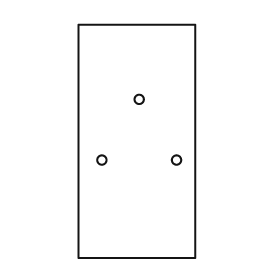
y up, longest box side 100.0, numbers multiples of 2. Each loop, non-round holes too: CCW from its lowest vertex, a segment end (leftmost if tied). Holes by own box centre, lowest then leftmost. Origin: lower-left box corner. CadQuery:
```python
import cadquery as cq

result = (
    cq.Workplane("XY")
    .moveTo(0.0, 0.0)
    .lineTo(50.0, 0.0)
    .lineTo(50.0, 100.0)
    .lineTo(0.0, 100.0)
    .close()
    .moveTo(10.0, 42.0)
    .circle(2.0)
    .moveTo(42.0, 42.0)
    .circle(2.0)
    .moveTo(26.0, 68.0)
    .circle(2.0)
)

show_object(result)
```